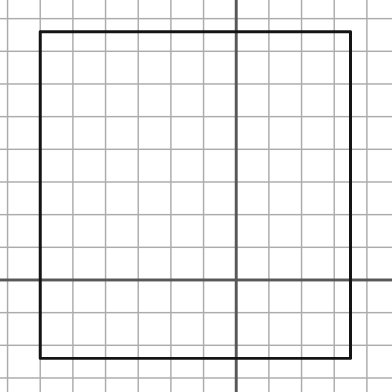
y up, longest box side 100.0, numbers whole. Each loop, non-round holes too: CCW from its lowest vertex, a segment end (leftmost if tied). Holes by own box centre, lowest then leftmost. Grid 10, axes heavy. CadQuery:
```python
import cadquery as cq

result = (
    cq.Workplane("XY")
    .moveTo(-60.0, -24.0)
    .lineTo(35.0, -24.0)
    .lineTo(35.0, 76.0)
    .lineTo(-60.0, 76.0)
    .close()
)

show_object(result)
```